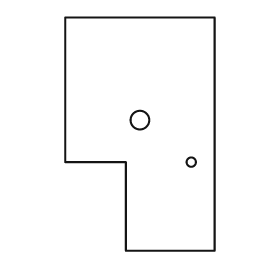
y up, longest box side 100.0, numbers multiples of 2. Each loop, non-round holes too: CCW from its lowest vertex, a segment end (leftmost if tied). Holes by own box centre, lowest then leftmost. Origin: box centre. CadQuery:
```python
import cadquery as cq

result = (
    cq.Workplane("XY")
    .moveTo(-6.0, -50.0)
    .lineTo(32.0, -50.0)
    .lineTo(32.0, 50.0)
    .lineTo(-32.0, 50.0)
    .lineTo(-32.0, -12.0)
    .lineTo(-6.0, -12.0)
    .close()
    .moveTo(22.0, -12.0)
    .circle(2.0)
    .moveTo(0.0, 6.0)
    .circle(4.0)
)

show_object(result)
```